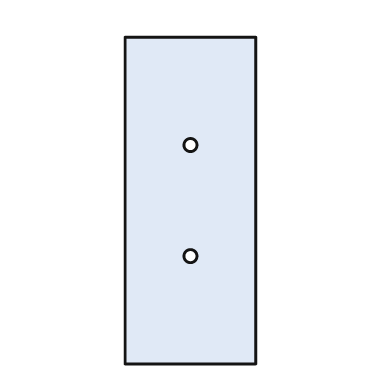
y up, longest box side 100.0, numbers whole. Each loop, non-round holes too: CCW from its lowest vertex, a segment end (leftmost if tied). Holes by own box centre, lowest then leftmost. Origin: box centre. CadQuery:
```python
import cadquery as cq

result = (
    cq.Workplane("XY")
    .moveTo(-20.0, -50.0)
    .lineTo(20.0, -50.0)
    .lineTo(20.0, 50.0)
    .lineTo(-20.0, 50.0)
    .close()
    .moveTo(0.0, -17.0)
    .circle(2.0)
    .moveTo(0.0, 17.0)
    .circle(2.0)
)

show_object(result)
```